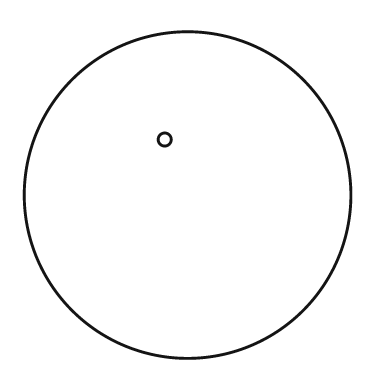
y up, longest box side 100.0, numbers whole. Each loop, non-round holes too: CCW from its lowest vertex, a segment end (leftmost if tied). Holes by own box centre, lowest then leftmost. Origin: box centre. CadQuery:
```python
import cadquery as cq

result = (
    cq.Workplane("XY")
    .moveTo(0.0, 0.0)
    .circle(50.0)
    .moveTo(-7.0, 17.0)
    .circle(2.0)
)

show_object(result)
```